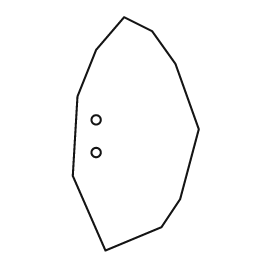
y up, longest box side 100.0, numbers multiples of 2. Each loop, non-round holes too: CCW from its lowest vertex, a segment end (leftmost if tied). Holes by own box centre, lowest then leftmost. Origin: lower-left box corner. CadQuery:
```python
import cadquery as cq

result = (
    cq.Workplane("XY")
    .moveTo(14.0, 0.0)
    .lineTo(38.0, 10.0)
    .lineTo(46.0, 22.0)
    .lineTo(54.0, 52.0)
    .lineTo(44.0, 80.0)
    .lineTo(34.0, 94.0)
    .lineTo(22.0, 100.0)
    .lineTo(10.0, 86.0)
    .lineTo(2.0, 66.0)
    .lineTo(0.0, 32.0)
    .close()
    .moveTo(10.0, 42.0)
    .circle(2.0)
    .moveTo(10.0, 56.0)
    .circle(2.0)
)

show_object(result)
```